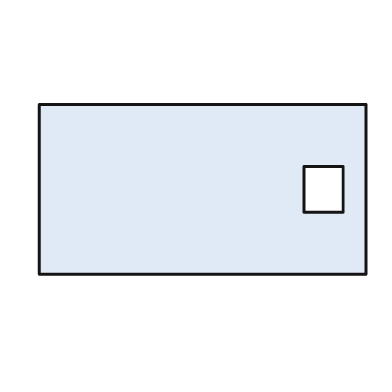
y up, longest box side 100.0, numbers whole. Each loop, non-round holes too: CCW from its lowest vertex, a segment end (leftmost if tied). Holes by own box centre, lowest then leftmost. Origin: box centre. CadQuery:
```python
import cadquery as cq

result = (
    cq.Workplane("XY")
    .moveTo(-50.0, -26.0)
    .lineTo(50.0, -26.0)
    .lineTo(50.0, 26.0)
    .lineTo(-50.0, 26.0)
    .close()
    .moveTo(31.0, -7.0)
    .lineTo(43.0, -7.0)
    .lineTo(43.0, 7.0)
    .lineTo(31.0, 7.0)
    .close()
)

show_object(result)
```